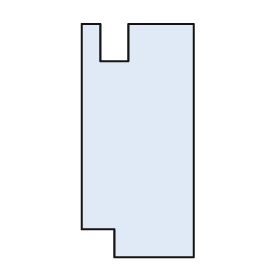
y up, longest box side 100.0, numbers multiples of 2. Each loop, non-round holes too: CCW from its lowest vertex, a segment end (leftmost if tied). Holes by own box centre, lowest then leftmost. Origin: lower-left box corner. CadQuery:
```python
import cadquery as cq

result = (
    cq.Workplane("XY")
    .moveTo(14.0, 0.0)
    .lineTo(48.0, 0.0)
    .lineTo(48.0, 100.0)
    .lineTo(20.0, 100.0)
    .lineTo(20.0, 84.0)
    .lineTo(8.0, 84.0)
    .lineTo(8.0, 100.0)
    .lineTo(0.0, 100.0)
    .lineTo(0.0, 12.0)
    .lineTo(14.0, 12.0)
    .close()
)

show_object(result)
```